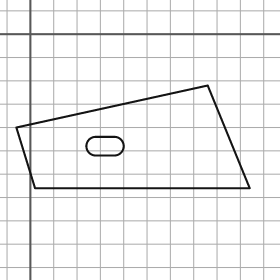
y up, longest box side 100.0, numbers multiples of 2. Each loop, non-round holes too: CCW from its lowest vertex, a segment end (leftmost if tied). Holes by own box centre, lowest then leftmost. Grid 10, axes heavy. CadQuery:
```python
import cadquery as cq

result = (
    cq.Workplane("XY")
    .moveTo(2.0, -66.0)
    .lineTo(94.0, -66.0)
    .lineTo(76.0, -22.0)
    .lineTo(-6.0, -40.0)
    .close()
    .moveTo(28.0, -52.0)
    .lineTo(36.0, -52.0)
    .threePointArc((40.0, -48.0), (36.0, -44.0))
    .lineTo(28.0, -44.0)
    .threePointArc((24.0, -48.0), (28.0, -52.0))
    .close()
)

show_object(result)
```